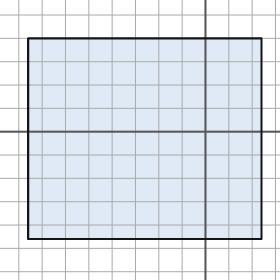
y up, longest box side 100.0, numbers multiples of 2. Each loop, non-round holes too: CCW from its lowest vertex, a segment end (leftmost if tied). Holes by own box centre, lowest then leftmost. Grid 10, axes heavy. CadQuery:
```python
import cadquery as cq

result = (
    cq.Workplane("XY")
    .moveTo(-76.0, -46.0)
    .lineTo(24.0, -46.0)
    .lineTo(24.0, 40.0)
    .lineTo(-76.0, 40.0)
    .close()
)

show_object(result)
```